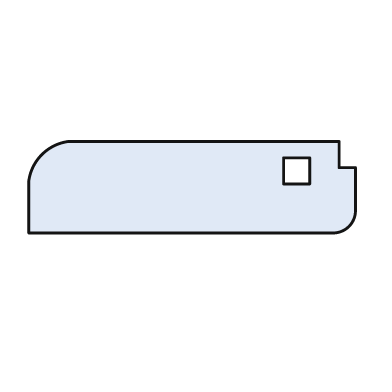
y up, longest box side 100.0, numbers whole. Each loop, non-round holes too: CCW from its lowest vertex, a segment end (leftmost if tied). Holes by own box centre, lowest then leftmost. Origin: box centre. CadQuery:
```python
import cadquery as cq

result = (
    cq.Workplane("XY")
    .moveTo(-50.0, -14.0)
    .lineTo(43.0, -14.0)
    .threePointArc((48.0, -12.0), (50.0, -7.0))
    .lineTo(50.0, 6.0)
    .lineTo(45.0, 6.0)
    .lineTo(45.0, 14.0)
    .lineTo(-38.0, 14.0)
    .threePointArc((-46.0, 10.0), (-50.0, 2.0))
    .close()
    .moveTo(28.0, 1.0)
    .lineTo(36.0, 1.0)
    .lineTo(36.0, 9.0)
    .lineTo(28.0, 9.0)
    .close()
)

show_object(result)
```